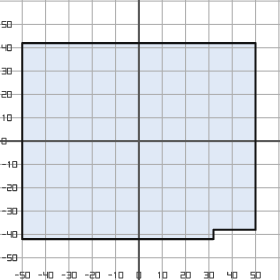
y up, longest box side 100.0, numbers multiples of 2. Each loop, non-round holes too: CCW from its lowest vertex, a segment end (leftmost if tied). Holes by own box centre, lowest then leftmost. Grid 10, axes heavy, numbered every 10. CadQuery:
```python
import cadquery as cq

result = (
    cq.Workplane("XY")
    .moveTo(-50.0, -42.0)
    .lineTo(32.0, -42.0)
    .lineTo(32.0, -38.0)
    .lineTo(50.0, -38.0)
    .lineTo(50.0, 42.0)
    .lineTo(-50.0, 42.0)
    .close()
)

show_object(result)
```